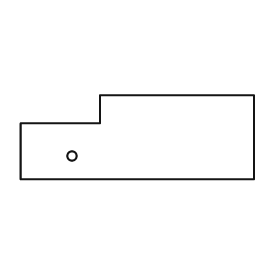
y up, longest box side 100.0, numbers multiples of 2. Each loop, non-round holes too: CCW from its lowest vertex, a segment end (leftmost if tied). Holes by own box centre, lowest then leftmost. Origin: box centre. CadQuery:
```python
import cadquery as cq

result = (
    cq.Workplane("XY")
    .moveTo(-50.0, -18.0)
    .lineTo(50.0, -18.0)
    .lineTo(50.0, 18.0)
    .lineTo(-16.0, 18.0)
    .lineTo(-16.0, 6.0)
    .lineTo(-50.0, 6.0)
    .close()
    .moveTo(-28.0, -8.0)
    .circle(2.0)
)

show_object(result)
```